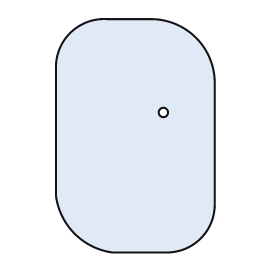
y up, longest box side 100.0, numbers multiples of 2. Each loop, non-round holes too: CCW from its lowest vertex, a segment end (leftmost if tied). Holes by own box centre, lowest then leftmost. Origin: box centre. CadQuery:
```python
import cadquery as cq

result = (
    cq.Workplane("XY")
    .moveTo(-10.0, -50.0)
    .lineTo(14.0, -50.0)
    .threePointArc((28.0, -44.0), (34.0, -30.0))
    .lineTo(34.0, 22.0)
    .threePointArc((26.0, 42.0), (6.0, 50.0))
    .lineTo(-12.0, 50.0)
    .threePointArc((-28.0, 44.0), (-34.0, 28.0))
    .lineTo(-34.0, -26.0)
    .threePointArc((-26.0, -42.0), (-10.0, -50.0))
    .close()
    .moveTo(12.0, 10.0)
    .circle(2.0)
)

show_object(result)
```